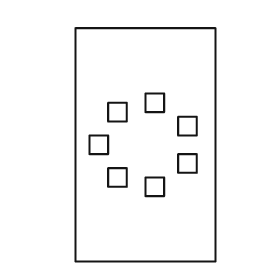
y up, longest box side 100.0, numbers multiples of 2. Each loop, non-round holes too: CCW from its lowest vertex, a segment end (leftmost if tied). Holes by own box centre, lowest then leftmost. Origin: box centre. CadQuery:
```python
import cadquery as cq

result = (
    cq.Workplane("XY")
    .moveTo(-30.0, -50.0)
    .lineTo(30.0, -50.0)
    .lineTo(30.0, 50.0)
    .lineTo(-30.0, 50.0)
    .close()
    .moveTo(0.0, -22.0)
    .lineTo(8.0, -22.0)
    .lineTo(8.0, -14.0)
    .lineTo(0.0, -14.0)
    .close()
    .moveTo(-16.0, -18.0)
    .lineTo(-8.0, -18.0)
    .lineTo(-8.0, -10.0)
    .lineTo(-16.0, -10.0)
    .close()
    .moveTo(14.0, -12.0)
    .lineTo(22.0, -12.0)
    .lineTo(22.0, -4.0)
    .lineTo(14.0, -4.0)
    .close()
    .moveTo(-24.0, -4.0)
    .lineTo(-16.0, -4.0)
    .lineTo(-16.0, 4.0)
    .lineTo(-24.0, 4.0)
    .close()
    .moveTo(14.0, 4.0)
    .lineTo(22.0, 4.0)
    .lineTo(22.0, 12.0)
    .lineTo(14.0, 12.0)
    .close()
    .moveTo(-16.0, 10.0)
    .lineTo(-8.0, 10.0)
    .lineTo(-8.0, 18.0)
    .lineTo(-16.0, 18.0)
    .close()
    .moveTo(0.0, 14.0)
    .lineTo(8.0, 14.0)
    .lineTo(8.0, 22.0)
    .lineTo(0.0, 22.0)
    .close()
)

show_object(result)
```